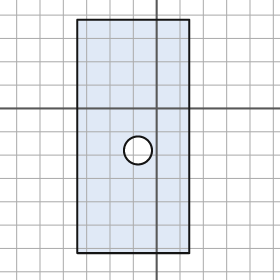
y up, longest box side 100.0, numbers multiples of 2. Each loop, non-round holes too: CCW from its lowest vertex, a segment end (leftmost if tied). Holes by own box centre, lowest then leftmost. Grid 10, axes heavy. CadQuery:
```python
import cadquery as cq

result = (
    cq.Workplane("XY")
    .moveTo(-34.0, -62.0)
    .lineTo(14.0, -62.0)
    .lineTo(14.0, 38.0)
    .lineTo(-34.0, 38.0)
    .close()
    .moveTo(-8.0, -18.0)
    .circle(6.0)
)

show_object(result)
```